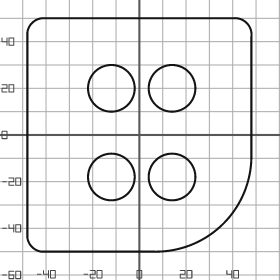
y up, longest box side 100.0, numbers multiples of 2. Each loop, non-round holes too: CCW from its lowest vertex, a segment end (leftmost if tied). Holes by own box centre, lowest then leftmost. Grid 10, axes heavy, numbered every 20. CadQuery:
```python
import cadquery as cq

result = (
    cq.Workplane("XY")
    .moveTo(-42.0, -50.0)
    .lineTo(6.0, -50.0)
    .threePointArc((36.0, -38.0), (48.0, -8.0))
    .lineTo(48.0, 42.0)
    .threePointArc((46.0, 48.0), (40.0, 50.0))
    .lineTo(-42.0, 50.0)
    .threePointArc((-46.0, 48.0), (-48.0, 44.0))
    .lineTo(-48.0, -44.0)
    .threePointArc((-46.0, -48.0), (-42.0, -50.0))
    .close()
    .moveTo(-12.0, -18.0)
    .circle(10.0)
    .moveTo(14.0, -18.0)
    .circle(10.0)
    .moveTo(-12.0, 20.0)
    .circle(10.0)
    .moveTo(14.0, 20.0)
    .circle(10.0)
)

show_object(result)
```